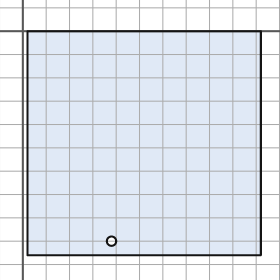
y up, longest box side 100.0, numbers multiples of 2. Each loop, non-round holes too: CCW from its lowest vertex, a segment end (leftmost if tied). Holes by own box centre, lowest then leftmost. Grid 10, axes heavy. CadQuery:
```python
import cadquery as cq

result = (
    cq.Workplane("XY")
    .moveTo(2.0, -96.0)
    .lineTo(102.0, -96.0)
    .lineTo(102.0, 0.0)
    .lineTo(2.0, 0.0)
    .close()
    .moveTo(38.0, -90.0)
    .circle(2.0)
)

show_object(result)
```